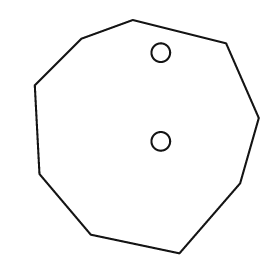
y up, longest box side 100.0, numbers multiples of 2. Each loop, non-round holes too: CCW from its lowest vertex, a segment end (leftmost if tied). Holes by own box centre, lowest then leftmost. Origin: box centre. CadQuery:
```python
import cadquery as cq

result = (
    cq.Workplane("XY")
    .moveTo(14.0, -50.0)
    .lineTo(40.0, -20.0)
    .lineTo(48.0, 8.0)
    .lineTo(34.0, 40.0)
    .lineTo(-6.0, 50.0)
    .lineTo(-28.0, 42.0)
    .lineTo(-48.0, 22.0)
    .lineTo(-46.0, -16.0)
    .lineTo(-24.0, -42.0)
    .close()
    .moveTo(6.0, -2.0)
    .circle(4.0)
    .moveTo(6.0, 36.0)
    .circle(4.0)
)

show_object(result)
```